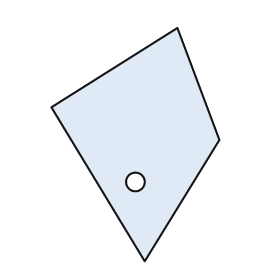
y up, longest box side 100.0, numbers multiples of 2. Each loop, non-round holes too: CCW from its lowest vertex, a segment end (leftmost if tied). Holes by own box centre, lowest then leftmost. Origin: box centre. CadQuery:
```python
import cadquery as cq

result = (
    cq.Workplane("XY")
    .moveTo(4.0, -50.0)
    .lineTo(36.0, 2.0)
    .lineTo(18.0, 50.0)
    .lineTo(-36.0, 16.0)
    .close()
    .moveTo(0.0, -16.0)
    .circle(4.0)
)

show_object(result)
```